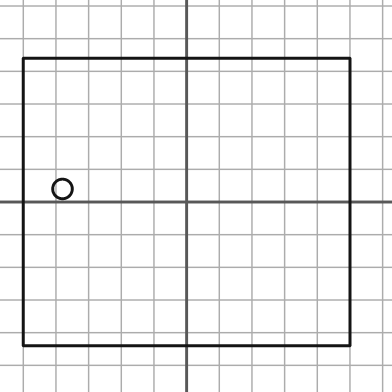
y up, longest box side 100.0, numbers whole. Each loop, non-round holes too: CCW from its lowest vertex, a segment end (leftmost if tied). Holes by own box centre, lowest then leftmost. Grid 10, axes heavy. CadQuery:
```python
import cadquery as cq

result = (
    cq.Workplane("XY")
    .moveTo(-50.0, -44.0)
    .lineTo(50.0, -44.0)
    .lineTo(50.0, 44.0)
    .lineTo(-50.0, 44.0)
    .close()
    .moveTo(-38.0, 4.0)
    .circle(3.0)
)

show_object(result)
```